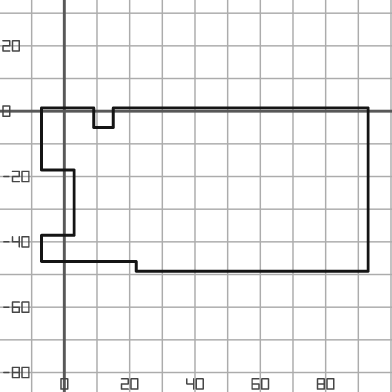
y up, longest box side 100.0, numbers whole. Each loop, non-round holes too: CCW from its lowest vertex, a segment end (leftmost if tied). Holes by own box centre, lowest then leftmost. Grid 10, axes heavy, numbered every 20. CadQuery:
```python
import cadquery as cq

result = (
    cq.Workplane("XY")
    .moveTo(22.0, -49.0)
    .lineTo(93.0, -49.0)
    .lineTo(93.0, 1.0)
    .lineTo(15.0, 1.0)
    .lineTo(15.0, -5.0)
    .lineTo(9.0, -5.0)
    .lineTo(9.0, 1.0)
    .lineTo(-7.0, 1.0)
    .lineTo(-7.0, -18.0)
    .lineTo(3.0, -18.0)
    .lineTo(3.0, -38.0)
    .lineTo(-7.0, -38.0)
    .lineTo(-7.0, -46.0)
    .lineTo(22.0, -46.0)
    .close()
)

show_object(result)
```